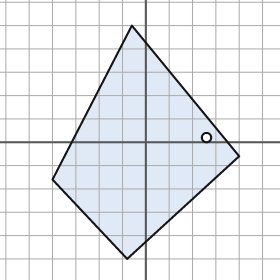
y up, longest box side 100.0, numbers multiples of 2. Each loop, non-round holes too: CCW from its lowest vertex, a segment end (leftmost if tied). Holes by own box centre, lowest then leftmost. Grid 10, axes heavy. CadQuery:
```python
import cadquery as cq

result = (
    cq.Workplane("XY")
    .moveTo(-8.0, -50.0)
    .lineTo(40.0, -6.0)
    .lineTo(-6.0, 50.0)
    .lineTo(-40.0, -16.0)
    .close()
    .moveTo(26.0, 2.0)
    .circle(2.0)
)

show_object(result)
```